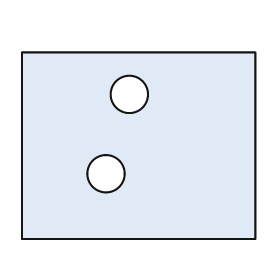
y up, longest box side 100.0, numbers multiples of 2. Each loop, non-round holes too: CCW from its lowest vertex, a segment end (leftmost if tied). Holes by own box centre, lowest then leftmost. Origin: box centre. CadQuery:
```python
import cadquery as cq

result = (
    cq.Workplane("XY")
    .moveTo(-50.0, -40.0)
    .lineTo(50.0, -40.0)
    .lineTo(50.0, 40.0)
    .lineTo(-50.0, 40.0)
    .close()
    .moveTo(-14.0, -12.0)
    .circle(8.0)
    .moveTo(-4.0, 22.0)
    .circle(8.0)
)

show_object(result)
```